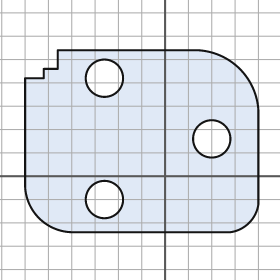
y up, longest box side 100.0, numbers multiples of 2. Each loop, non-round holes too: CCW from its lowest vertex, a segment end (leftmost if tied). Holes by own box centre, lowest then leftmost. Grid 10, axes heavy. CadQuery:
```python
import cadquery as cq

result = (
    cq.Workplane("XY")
    .moveTo(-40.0, -24.0)
    .lineTo(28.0, -24.0)
    .threePointArc((36.0, -20.0), (40.0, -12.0))
    .lineTo(40.0, 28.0)
    .threePointArc((32.0, 46.0), (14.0, 54.0))
    .lineTo(-46.0, 54.0)
    .lineTo(-46.0, 46.0)
    .lineTo(-52.0, 46.0)
    .lineTo(-52.0, 42.0)
    .lineTo(-60.0, 42.0)
    .lineTo(-60.0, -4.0)
    .threePointArc((-54.0, -18.0), (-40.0, -24.0))
    .close()
    .moveTo(-26.0, -10.0)
    .circle(8.0)
    .moveTo(20.0, 16.0)
    .circle(8.0)
    .moveTo(-26.0, 42.0)
    .circle(8.0)
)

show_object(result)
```